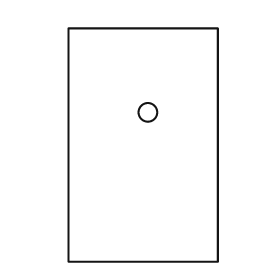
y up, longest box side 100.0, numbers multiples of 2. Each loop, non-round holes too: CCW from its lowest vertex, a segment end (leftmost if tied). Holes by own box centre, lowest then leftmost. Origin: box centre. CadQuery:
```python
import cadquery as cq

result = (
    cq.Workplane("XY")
    .moveTo(-32.0, -50.0)
    .lineTo(32.0, -50.0)
    .lineTo(32.0, 50.0)
    .lineTo(-32.0, 50.0)
    .close()
    .moveTo(2.0, 14.0)
    .circle(4.0)
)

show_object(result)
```